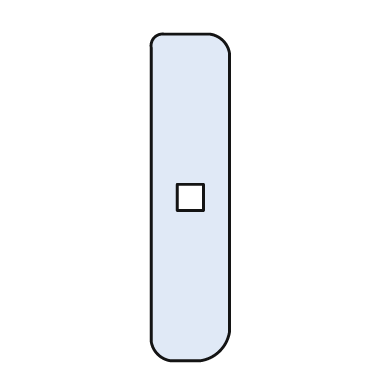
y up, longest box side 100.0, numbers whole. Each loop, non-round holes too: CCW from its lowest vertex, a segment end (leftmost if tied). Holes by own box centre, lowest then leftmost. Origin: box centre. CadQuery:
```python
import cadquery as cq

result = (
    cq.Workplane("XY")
    .moveTo(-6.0, -50.0)
    .lineTo(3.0, -50.0)
    .threePointArc((9.0, -47.0), (12.0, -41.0))
    .lineTo(12.0, 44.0)
    .threePointArc((10.0, 48.0), (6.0, 50.0))
    .lineTo(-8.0, 50.0)
    .threePointArc((-11.0, 49.0), (-12.0, 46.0))
    .lineTo(-12.0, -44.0)
    .threePointArc((-10.0, -48.0), (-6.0, -50.0))
    .close()
    .moveTo(-4.0, -4.0)
    .lineTo(4.0, -4.0)
    .lineTo(4.0, 4.0)
    .lineTo(-4.0, 4.0)
    .close()
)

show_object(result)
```